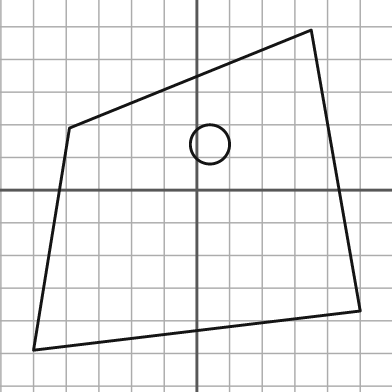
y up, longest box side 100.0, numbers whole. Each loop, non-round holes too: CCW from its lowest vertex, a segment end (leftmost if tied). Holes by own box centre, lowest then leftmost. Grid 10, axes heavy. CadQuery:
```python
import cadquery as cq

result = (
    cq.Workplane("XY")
    .moveTo(-50.0, -49.0)
    .lineTo(50.0, -37.0)
    .lineTo(35.0, 49.0)
    .lineTo(-39.0, 19.0)
    .close()
    .moveTo(4.0, 14.0)
    .circle(6.0)
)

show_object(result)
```